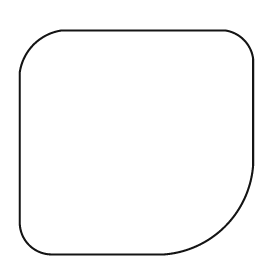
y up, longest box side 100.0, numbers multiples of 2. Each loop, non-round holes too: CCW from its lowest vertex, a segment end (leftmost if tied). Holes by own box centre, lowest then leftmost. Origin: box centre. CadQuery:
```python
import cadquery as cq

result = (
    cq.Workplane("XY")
    .moveTo(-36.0, -48.0)
    .lineTo(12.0, -48.0)
    .threePointArc((38.0, -36.0), (50.0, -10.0))
    .lineTo(50.0, 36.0)
    .threePointArc((46.0, 44.0), (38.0, 48.0))
    .lineTo(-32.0, 48.0)
    .threePointArc((-44.0, 42.0), (-50.0, 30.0))
    .lineTo(-50.0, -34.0)
    .threePointArc((-46.0, -44.0), (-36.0, -48.0))
    .close()
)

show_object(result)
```